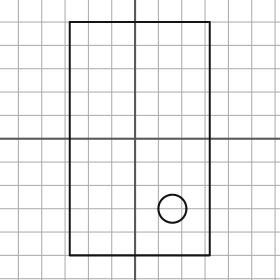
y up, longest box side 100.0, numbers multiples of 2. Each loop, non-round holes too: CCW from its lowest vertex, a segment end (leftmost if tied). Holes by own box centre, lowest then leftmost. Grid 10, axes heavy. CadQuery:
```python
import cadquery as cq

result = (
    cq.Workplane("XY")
    .moveTo(-28.0, -50.0)
    .lineTo(32.0, -50.0)
    .lineTo(32.0, 50.0)
    .lineTo(-28.0, 50.0)
    .close()
    .moveTo(16.0, -30.0)
    .circle(6.0)
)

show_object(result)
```